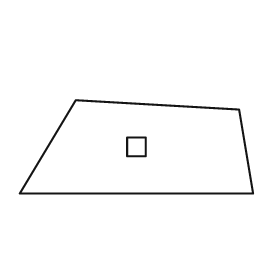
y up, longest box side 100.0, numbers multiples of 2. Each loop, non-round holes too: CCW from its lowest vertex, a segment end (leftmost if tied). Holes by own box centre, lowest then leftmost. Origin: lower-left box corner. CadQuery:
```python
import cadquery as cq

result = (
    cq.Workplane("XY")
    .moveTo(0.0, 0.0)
    .lineTo(100.0, 0.0)
    .lineTo(94.0, 36.0)
    .lineTo(24.0, 40.0)
    .close()
    .moveTo(46.0, 16.0)
    .lineTo(54.0, 16.0)
    .lineTo(54.0, 24.0)
    .lineTo(46.0, 24.0)
    .close()
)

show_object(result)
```